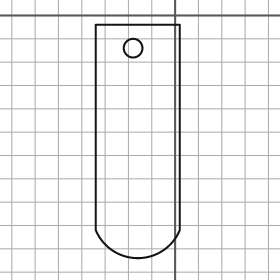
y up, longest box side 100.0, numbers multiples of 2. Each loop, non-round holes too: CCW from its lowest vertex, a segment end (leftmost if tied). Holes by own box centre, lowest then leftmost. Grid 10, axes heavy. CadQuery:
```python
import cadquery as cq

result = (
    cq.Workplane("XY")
    .moveTo(-34.0, -92.0)
    .threePointArc((-16.0, -104.0), (2.0, -92.0))
    .lineTo(2.0, -4.0)
    .lineTo(-34.0, -4.0)
    .close()
    .moveTo(-18.0, -14.0)
    .circle(4.0)
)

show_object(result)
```